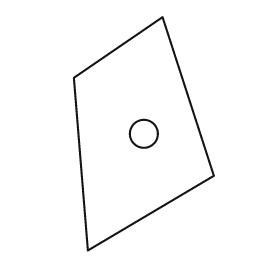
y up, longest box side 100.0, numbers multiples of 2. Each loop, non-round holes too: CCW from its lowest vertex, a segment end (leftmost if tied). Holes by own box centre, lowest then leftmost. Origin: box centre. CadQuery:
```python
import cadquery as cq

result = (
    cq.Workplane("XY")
    .moveTo(-24.0, -50.0)
    .lineTo(30.0, -18.0)
    .lineTo(8.0, 50.0)
    .lineTo(-30.0, 24.0)
    .close()
    .moveTo(0.0, 0.0)
    .circle(6.0)
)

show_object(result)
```